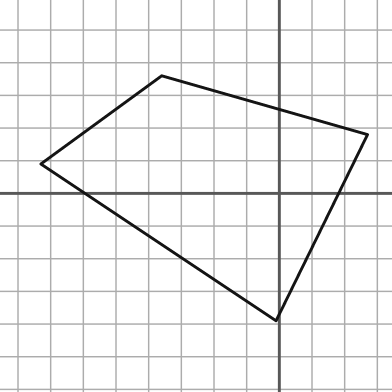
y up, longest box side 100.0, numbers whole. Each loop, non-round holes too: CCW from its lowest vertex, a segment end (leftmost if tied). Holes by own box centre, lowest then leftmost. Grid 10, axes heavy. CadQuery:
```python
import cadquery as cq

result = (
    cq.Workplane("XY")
    .moveTo(-1.0, -39.0)
    .lineTo(27.0, 18.0)
    .lineTo(-36.0, 36.0)
    .lineTo(-73.0, 9.0)
    .close()
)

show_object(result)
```